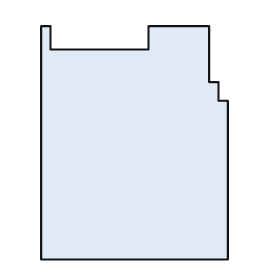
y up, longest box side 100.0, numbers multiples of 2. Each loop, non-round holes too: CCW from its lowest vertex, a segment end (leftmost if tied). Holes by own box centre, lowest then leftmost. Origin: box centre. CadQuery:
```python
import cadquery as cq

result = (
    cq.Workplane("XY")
    .moveTo(-40.0, -50.0)
    .lineTo(40.0, -50.0)
    .lineTo(40.0, 18.0)
    .lineTo(36.0, 18.0)
    .lineTo(36.0, 26.0)
    .lineTo(32.0, 26.0)
    .lineTo(32.0, 50.0)
    .lineTo(6.0, 50.0)
    .lineTo(6.0, 40.0)
    .lineTo(-36.0, 40.0)
    .lineTo(-36.0, 50.0)
    .lineTo(-40.0, 50.0)
    .close()
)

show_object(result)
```